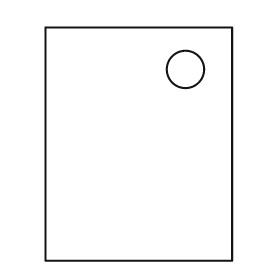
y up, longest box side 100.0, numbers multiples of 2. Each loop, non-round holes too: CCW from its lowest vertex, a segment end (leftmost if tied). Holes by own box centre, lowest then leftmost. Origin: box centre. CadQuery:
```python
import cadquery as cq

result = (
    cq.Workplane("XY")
    .moveTo(-40.0, -50.0)
    .lineTo(40.0, -50.0)
    .lineTo(40.0, 50.0)
    .lineTo(-40.0, 50.0)
    .close()
    .moveTo(20.0, 32.0)
    .circle(8.0)
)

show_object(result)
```